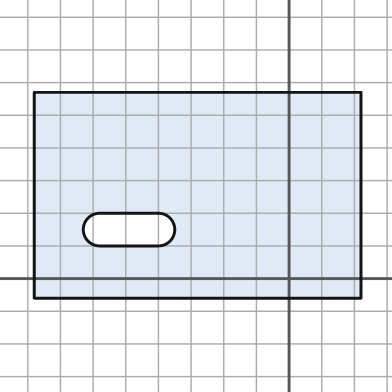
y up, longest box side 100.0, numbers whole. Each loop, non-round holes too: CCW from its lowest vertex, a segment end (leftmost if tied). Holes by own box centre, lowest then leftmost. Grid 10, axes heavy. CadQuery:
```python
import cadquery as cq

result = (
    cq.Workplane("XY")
    .moveTo(-78.0, -6.0)
    .lineTo(22.0, -6.0)
    .lineTo(22.0, 57.0)
    .lineTo(-78.0, 57.0)
    .close()
    .moveTo(-58.0, 10.0)
    .lineTo(-40.0, 10.0)
    .threePointArc((-35.0, 15.0), (-40.0, 20.0))
    .lineTo(-58.0, 20.0)
    .threePointArc((-63.0, 15.0), (-58.0, 10.0))
    .close()
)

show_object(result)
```